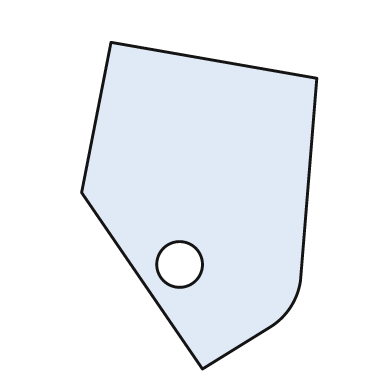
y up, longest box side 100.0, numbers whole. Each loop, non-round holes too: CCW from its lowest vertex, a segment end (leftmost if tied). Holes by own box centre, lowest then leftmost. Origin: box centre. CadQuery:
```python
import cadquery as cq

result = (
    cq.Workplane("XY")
    .moveTo(1.0, -50.0)
    .lineTo(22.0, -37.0)
    .threePointArc((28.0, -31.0), (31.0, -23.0))
    .lineTo(36.0, 39.0)
    .lineTo(-27.0, 50.0)
    .lineTo(-36.0, 4.0)
    .close()
    .moveTo(-6.0, -18.0)
    .circle(7.0)
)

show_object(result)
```